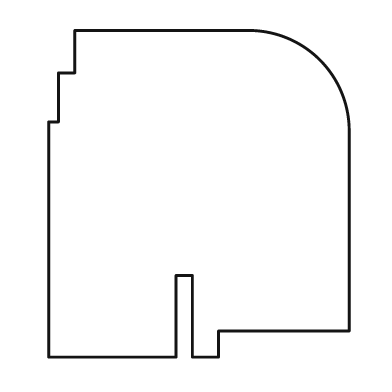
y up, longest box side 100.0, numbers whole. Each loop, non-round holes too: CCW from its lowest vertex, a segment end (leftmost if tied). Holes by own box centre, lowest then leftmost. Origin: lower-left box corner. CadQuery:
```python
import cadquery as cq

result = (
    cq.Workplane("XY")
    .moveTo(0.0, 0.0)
    .lineTo(39.0, 0.0)
    .lineTo(39.0, 25.0)
    .lineTo(44.0, 25.0)
    .lineTo(44.0, 0.0)
    .lineTo(52.0, 0.0)
    .lineTo(52.0, 8.0)
    .lineTo(92.0, 8.0)
    .lineTo(92.0, 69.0)
    .threePointArc((83.0, 91.0), (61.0, 100.0))
    .lineTo(8.0, 100.0)
    .lineTo(8.0, 87.0)
    .lineTo(3.0, 87.0)
    .lineTo(3.0, 72.0)
    .lineTo(0.0, 72.0)
    .close()
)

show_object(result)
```